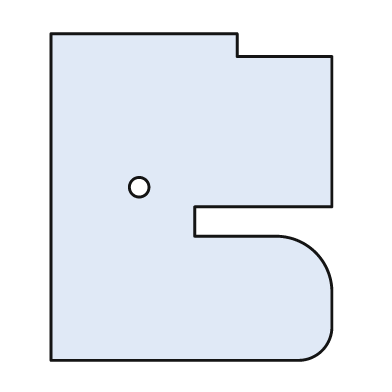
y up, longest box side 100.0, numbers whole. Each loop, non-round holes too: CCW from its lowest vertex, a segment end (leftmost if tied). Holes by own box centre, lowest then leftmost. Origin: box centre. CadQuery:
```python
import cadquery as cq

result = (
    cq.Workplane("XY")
    .moveTo(-43.0, -50.0)
    .lineTo(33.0, -50.0)
    .threePointArc((40.0, -47.0), (43.0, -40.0))
    .lineTo(43.0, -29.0)
    .threePointArc((38.0, -17.0), (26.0, -12.0))
    .lineTo(1.0, -12.0)
    .lineTo(1.0, -3.0)
    .lineTo(43.0, -3.0)
    .lineTo(43.0, 43.0)
    .lineTo(14.0, 43.0)
    .lineTo(14.0, 50.0)
    .lineTo(-43.0, 50.0)
    .close()
    .moveTo(-16.0, 3.0)
    .circle(3.0)
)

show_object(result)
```